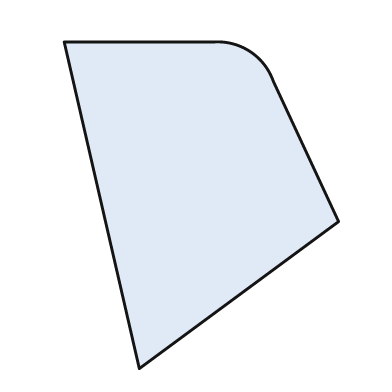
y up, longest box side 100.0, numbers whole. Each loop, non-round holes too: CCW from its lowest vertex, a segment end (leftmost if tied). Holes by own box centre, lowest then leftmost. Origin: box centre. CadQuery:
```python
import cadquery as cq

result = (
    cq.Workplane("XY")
    .moveTo(-19.0, -50.0)
    .lineTo(42.0, -5.0)
    .lineTo(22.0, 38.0)
    .threePointArc((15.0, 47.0), (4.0, 50.0))
    .lineTo(-42.0, 50.0)
    .close()
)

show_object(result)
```